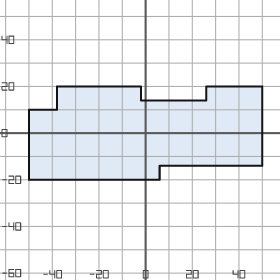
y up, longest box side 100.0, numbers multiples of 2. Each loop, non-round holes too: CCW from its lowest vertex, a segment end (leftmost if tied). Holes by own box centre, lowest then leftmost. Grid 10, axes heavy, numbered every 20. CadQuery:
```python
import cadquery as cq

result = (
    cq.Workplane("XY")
    .moveTo(-50.0, -20.0)
    .lineTo(6.0, -20.0)
    .lineTo(6.0, -14.0)
    .lineTo(50.0, -14.0)
    .lineTo(50.0, 20.0)
    .lineTo(26.0, 20.0)
    .lineTo(26.0, 14.0)
    .lineTo(-2.0, 14.0)
    .lineTo(-2.0, 20.0)
    .lineTo(-38.0, 20.0)
    .lineTo(-38.0, 10.0)
    .lineTo(-50.0, 10.0)
    .close()
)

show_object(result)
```